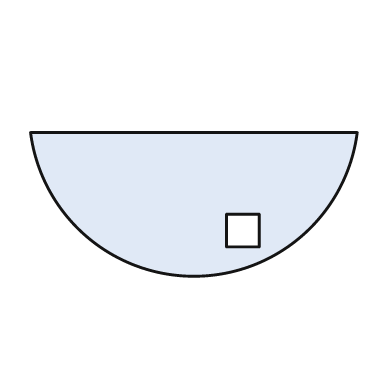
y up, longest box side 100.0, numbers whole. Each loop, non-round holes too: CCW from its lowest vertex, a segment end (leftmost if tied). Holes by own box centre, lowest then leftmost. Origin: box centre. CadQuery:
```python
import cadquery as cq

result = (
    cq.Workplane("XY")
    .moveTo(-50.0, 22.0)
    .threePointArc((0.0, -22.0), (50.0, 22.0))
    .close()
    .moveTo(10.0, -13.0)
    .lineTo(20.0, -13.0)
    .lineTo(20.0, -3.0)
    .lineTo(10.0, -3.0)
    .close()
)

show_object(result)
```